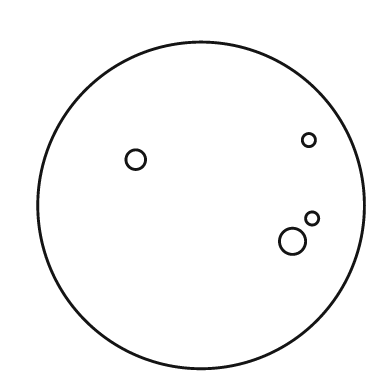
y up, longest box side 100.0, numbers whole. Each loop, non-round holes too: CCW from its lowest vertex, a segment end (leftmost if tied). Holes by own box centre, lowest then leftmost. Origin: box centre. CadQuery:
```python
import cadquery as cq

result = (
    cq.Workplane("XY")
    .moveTo(0.0, 0.0)
    .circle(50.0)
    .moveTo(28.0, -11.0)
    .circle(4.0)
    .moveTo(34.0, -4.0)
    .circle(2.0)
    .moveTo(-20.0, 14.0)
    .circle(3.0)
    .moveTo(33.0, 20.0)
    .circle(2.0)
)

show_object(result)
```